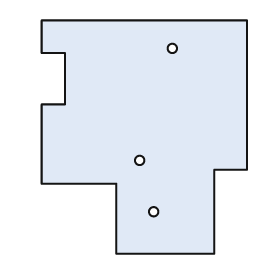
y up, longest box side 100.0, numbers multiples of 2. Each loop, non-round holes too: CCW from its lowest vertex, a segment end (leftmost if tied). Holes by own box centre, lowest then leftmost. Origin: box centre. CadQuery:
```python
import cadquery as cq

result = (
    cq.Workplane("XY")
    .moveTo(-12.0, -50.0)
    .lineTo(30.0, -50.0)
    .lineTo(30.0, -14.0)
    .lineTo(44.0, -14.0)
    .lineTo(44.0, 50.0)
    .lineTo(-44.0, 50.0)
    .lineTo(-44.0, 36.0)
    .lineTo(-34.0, 36.0)
    .lineTo(-34.0, 14.0)
    .lineTo(-44.0, 14.0)
    .lineTo(-44.0, -20.0)
    .lineTo(-12.0, -20.0)
    .close()
    .moveTo(4.0, -32.0)
    .circle(2.0)
    .moveTo(-2.0, -10.0)
    .circle(2.0)
    .moveTo(12.0, 38.0)
    .circle(2.0)
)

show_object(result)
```